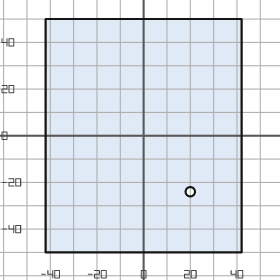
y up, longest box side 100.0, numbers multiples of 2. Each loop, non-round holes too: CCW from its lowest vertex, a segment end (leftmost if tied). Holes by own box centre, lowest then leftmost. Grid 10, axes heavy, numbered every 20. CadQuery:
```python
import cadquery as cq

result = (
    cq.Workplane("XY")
    .moveTo(-42.0, -50.0)
    .lineTo(42.0, -50.0)
    .lineTo(42.0, 50.0)
    .lineTo(-42.0, 50.0)
    .close()
    .moveTo(20.0, -24.0)
    .circle(2.0)
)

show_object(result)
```